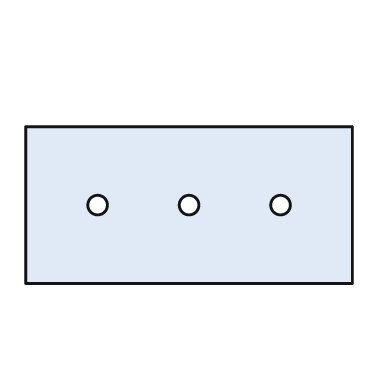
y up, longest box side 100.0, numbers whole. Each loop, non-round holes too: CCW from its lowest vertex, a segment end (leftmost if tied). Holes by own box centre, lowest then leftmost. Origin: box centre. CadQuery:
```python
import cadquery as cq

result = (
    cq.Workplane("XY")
    .moveTo(-50.0, -24.0)
    .lineTo(50.0, -24.0)
    .lineTo(50.0, 24.0)
    .lineTo(-50.0, 24.0)
    .close()
    .moveTo(-28.0, 0.0)
    .circle(3.0)
    .moveTo(0.0, 0.0)
    .circle(3.0)
    .moveTo(28.0, 0.0)
    .circle(3.0)
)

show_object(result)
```